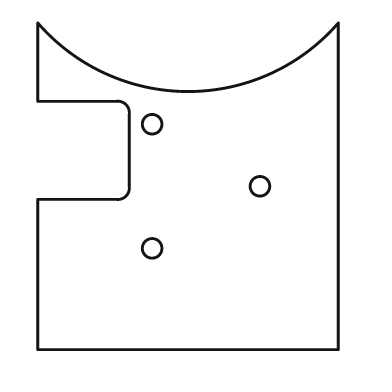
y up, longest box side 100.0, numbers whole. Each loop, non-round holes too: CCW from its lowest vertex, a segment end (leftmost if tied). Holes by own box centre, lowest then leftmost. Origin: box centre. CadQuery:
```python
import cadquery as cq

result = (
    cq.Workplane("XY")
    .moveTo(-46.0, -50.0)
    .lineTo(46.0, -50.0)
    .lineTo(46.0, 50.0)
    .threePointArc((0.0, 29.0), (-46.0, 50.0))
    .lineTo(-46.0, 26.0)
    .lineTo(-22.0, 26.0)
    .threePointArc((-19.0, 25.0), (-18.0, 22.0))
    .lineTo(-18.0, 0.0)
    .threePointArc((-19.0, -3.0), (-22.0, -4.0))
    .lineTo(-46.0, -4.0)
    .close()
    .moveTo(-11.0, -19.0)
    .circle(3.0)
    .moveTo(22.0, 0.0)
    .circle(3.0)
    .moveTo(-11.0, 19.0)
    .circle(3.0)
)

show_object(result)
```